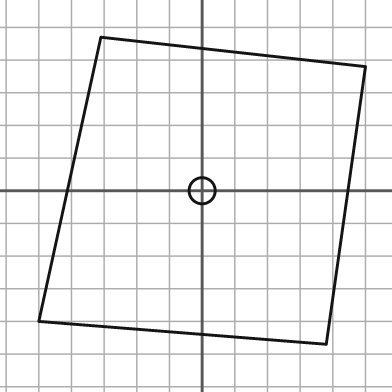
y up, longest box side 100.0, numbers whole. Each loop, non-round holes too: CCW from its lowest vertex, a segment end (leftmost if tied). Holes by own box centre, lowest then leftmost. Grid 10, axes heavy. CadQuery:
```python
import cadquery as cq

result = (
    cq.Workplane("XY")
    .moveTo(38.0, -47.0)
    .lineTo(50.0, 38.0)
    .lineTo(-31.0, 47.0)
    .lineTo(-50.0, -40.0)
    .close()
    .moveTo(0.0, 0.0)
    .circle(4.0)
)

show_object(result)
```